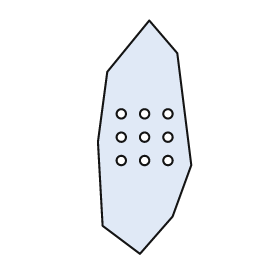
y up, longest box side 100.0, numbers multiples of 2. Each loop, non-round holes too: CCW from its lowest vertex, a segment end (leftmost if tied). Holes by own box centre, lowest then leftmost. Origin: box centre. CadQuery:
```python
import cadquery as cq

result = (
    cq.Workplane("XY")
    .moveTo(-2.0, -50.0)
    .lineTo(12.0, -34.0)
    .lineTo(20.0, -12.0)
    .lineTo(14.0, 36.0)
    .lineTo(2.0, 50.0)
    .lineTo(-16.0, 28.0)
    .lineTo(-20.0, -2.0)
    .lineTo(-18.0, -38.0)
    .close()
    .moveTo(-10.0, -10.0)
    .circle(2.0)
    .moveTo(0.0, -10.0)
    .circle(2.0)
    .moveTo(10.0, -10.0)
    .circle(2.0)
    .moveTo(-10.0, 0.0)
    .circle(2.0)
    .moveTo(0.0, 0.0)
    .circle(2.0)
    .moveTo(10.0, 0.0)
    .circle(2.0)
    .moveTo(-10.0, 10.0)
    .circle(2.0)
    .moveTo(0.0, 10.0)
    .circle(2.0)
    .moveTo(10.0, 10.0)
    .circle(2.0)
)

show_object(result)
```